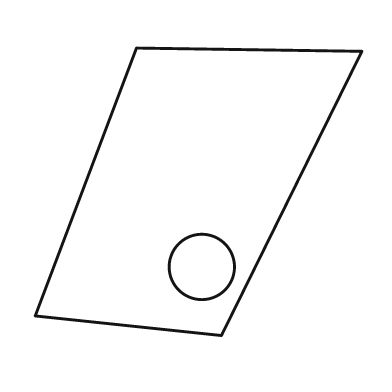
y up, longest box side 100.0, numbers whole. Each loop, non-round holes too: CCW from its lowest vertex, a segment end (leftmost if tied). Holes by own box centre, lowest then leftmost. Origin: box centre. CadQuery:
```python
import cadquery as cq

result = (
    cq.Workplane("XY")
    .moveTo(7.0, -44.0)
    .lineTo(50.0, 43.0)
    .lineTo(-19.0, 44.0)
    .lineTo(-50.0, -38.0)
    .close()
    .moveTo(1.0, -23.0)
    .circle(10.0)
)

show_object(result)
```